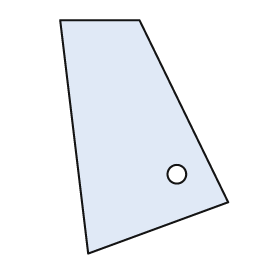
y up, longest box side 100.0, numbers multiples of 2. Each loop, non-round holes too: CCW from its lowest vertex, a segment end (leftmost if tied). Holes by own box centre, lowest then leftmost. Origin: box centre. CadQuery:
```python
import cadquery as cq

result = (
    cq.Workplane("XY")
    .moveTo(-24.0, -50.0)
    .lineTo(36.0, -28.0)
    .lineTo(-2.0, 50.0)
    .lineTo(-36.0, 50.0)
    .close()
    .moveTo(14.0, -16.0)
    .circle(4.0)
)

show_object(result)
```